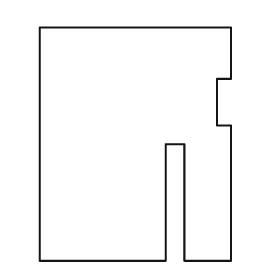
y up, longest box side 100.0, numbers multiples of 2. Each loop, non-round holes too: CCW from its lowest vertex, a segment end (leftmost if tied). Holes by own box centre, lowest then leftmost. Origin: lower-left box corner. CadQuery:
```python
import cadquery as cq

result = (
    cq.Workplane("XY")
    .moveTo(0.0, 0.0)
    .lineTo(54.0, 0.0)
    .lineTo(54.0, 50.0)
    .lineTo(62.0, 50.0)
    .lineTo(62.0, 0.0)
    .lineTo(82.0, 0.0)
    .lineTo(82.0, 58.0)
    .lineTo(76.0, 58.0)
    .lineTo(76.0, 78.0)
    .lineTo(82.0, 78.0)
    .lineTo(82.0, 100.0)
    .lineTo(0.0, 100.0)
    .close()
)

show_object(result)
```